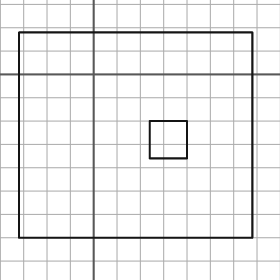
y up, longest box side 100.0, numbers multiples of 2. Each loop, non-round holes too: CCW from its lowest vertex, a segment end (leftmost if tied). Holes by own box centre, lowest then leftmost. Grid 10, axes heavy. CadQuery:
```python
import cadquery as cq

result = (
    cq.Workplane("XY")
    .moveTo(-32.0, -70.0)
    .lineTo(68.0, -70.0)
    .lineTo(68.0, 18.0)
    .lineTo(-32.0, 18.0)
    .close()
    .moveTo(24.0, -36.0)
    .lineTo(40.0, -36.0)
    .lineTo(40.0, -20.0)
    .lineTo(24.0, -20.0)
    .close()
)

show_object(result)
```